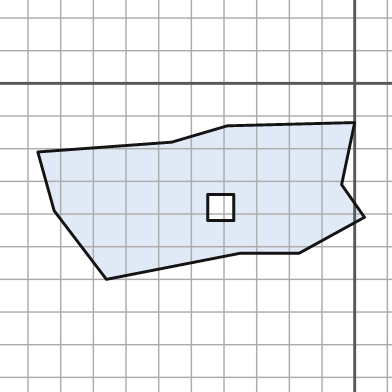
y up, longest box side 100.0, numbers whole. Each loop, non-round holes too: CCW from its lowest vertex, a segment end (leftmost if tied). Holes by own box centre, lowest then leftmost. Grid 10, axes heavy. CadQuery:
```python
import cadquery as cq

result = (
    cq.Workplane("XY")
    .moveTo(-76.0, -60.0)
    .lineTo(-35.0, -52.0)
    .lineTo(-17.0, -52.0)
    .lineTo(3.0, -41.0)
    .lineTo(-4.0, -31.0)
    .lineTo(0.0, -12.0)
    .lineTo(-39.0, -13.0)
    .lineTo(-56.0, -18.0)
    .lineTo(-97.0, -21.0)
    .lineTo(-92.0, -39.0)
    .close()
    .moveTo(-45.0, -42.0)
    .lineTo(-37.0, -42.0)
    .lineTo(-37.0, -34.0)
    .lineTo(-45.0, -34.0)
    .close()
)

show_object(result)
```